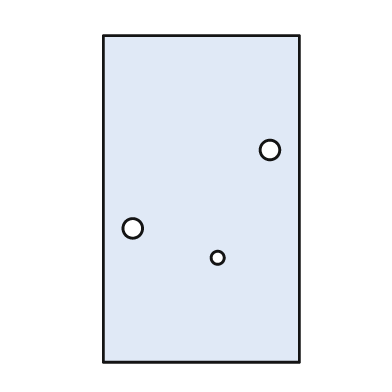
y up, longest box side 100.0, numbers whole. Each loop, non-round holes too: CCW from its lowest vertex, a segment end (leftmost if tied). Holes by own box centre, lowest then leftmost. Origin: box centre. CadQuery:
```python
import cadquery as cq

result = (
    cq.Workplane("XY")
    .moveTo(-30.0, -50.0)
    .lineTo(30.0, -50.0)
    .lineTo(30.0, 50.0)
    .lineTo(-30.0, 50.0)
    .close()
    .moveTo(5.0, -18.0)
    .circle(2.0)
    .moveTo(-21.0, -9.0)
    .circle(3.0)
    .moveTo(21.0, 15.0)
    .circle(3.0)
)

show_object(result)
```